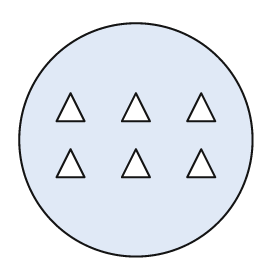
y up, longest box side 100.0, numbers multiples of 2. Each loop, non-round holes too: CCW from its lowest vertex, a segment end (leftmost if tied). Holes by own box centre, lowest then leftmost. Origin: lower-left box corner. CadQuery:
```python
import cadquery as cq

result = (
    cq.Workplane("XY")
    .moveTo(50.0, 50.0)
    .circle(50.0)
    .moveTo(16.0, 34.0)
    .lineTo(28.0, 34.0)
    .lineTo(22.0, 46.0)
    .close()
    .moveTo(44.0, 34.0)
    .lineTo(56.0, 34.0)
    .lineTo(50.0, 46.0)
    .close()
    .moveTo(72.0, 34.0)
    .lineTo(84.0, 34.0)
    .lineTo(78.0, 46.0)
    .close()
    .moveTo(16.0, 58.0)
    .lineTo(28.0, 58.0)
    .lineTo(22.0, 70.0)
    .close()
    .moveTo(44.0, 58.0)
    .lineTo(56.0, 58.0)
    .lineTo(50.0, 70.0)
    .close()
    .moveTo(72.0, 58.0)
    .lineTo(84.0, 58.0)
    .lineTo(78.0, 70.0)
    .close()
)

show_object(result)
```